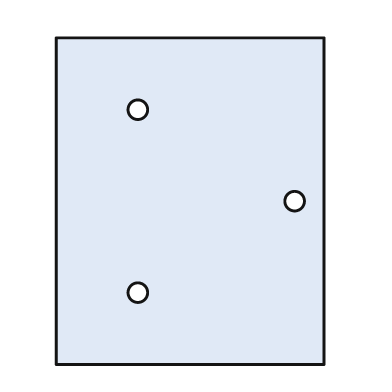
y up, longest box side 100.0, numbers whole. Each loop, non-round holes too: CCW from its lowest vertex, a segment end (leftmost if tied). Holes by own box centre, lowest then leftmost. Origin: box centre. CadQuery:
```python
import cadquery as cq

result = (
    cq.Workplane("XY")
    .moveTo(-41.0, -50.0)
    .lineTo(41.0, -50.0)
    .lineTo(41.0, 50.0)
    .lineTo(-41.0, 50.0)
    .close()
    .moveTo(-16.0, -28.0)
    .circle(3.0)
    .moveTo(32.0, 0.0)
    .circle(3.0)
    .moveTo(-16.0, 28.0)
    .circle(3.0)
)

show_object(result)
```